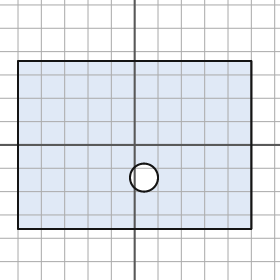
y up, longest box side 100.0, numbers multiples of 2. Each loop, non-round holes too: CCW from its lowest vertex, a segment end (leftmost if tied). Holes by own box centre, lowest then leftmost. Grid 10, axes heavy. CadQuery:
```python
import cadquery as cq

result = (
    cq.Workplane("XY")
    .moveTo(-50.0, -36.0)
    .lineTo(50.0, -36.0)
    .lineTo(50.0, 36.0)
    .lineTo(-50.0, 36.0)
    .close()
    .moveTo(4.0, -14.0)
    .circle(6.0)
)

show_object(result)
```